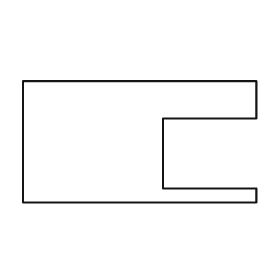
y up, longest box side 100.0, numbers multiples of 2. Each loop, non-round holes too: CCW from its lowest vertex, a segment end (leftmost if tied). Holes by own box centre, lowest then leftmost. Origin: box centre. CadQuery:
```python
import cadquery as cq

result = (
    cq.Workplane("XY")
    .moveTo(-50.0, -26.0)
    .lineTo(50.0, -26.0)
    .lineTo(50.0, -20.0)
    .lineTo(10.0, -20.0)
    .lineTo(10.0, 10.0)
    .lineTo(50.0, 10.0)
    .lineTo(50.0, 26.0)
    .lineTo(-50.0, 26.0)
    .close()
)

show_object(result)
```